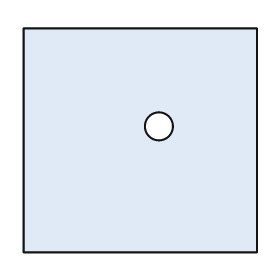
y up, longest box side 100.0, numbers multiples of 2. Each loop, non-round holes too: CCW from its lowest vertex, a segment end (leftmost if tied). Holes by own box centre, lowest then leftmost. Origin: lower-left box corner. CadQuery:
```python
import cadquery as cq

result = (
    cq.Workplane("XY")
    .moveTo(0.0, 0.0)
    .lineTo(100.0, 0.0)
    .lineTo(100.0, 96.0)
    .lineTo(0.0, 96.0)
    .close()
    .moveTo(58.0, 54.0)
    .circle(6.0)
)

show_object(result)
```